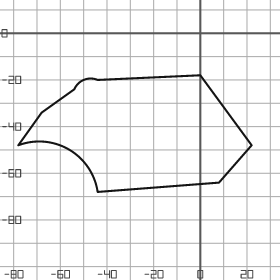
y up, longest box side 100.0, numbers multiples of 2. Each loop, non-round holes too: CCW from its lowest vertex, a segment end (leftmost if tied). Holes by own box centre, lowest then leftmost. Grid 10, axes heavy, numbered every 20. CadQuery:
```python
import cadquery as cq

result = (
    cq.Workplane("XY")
    .moveTo(-44.0, -68.0)
    .lineTo(8.0, -64.0)
    .lineTo(22.0, -48.0)
    .lineTo(0.0, -18.0)
    .lineTo(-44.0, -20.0)
    .threePointArc((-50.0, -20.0), (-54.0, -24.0))
    .lineTo(-68.0, -34.0)
    .lineTo(-78.0, -48.0)
    .threePointArc((-56.0, -50.0), (-44.0, -68.0))
    .close()
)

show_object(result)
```